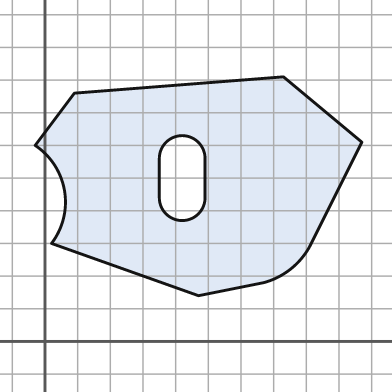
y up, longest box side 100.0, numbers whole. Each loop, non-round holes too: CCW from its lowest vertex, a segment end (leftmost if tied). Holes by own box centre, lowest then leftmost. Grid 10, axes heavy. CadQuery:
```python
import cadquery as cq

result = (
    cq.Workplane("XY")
    .moveTo(47.0, 14.0)
    .lineTo(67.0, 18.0)
    .threePointArc((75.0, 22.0), (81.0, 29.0))
    .lineTo(97.0, 61.0)
    .lineTo(73.0, 81.0)
    .lineTo(9.0, 76.0)
    .lineTo(-3.0, 60.0)
    .threePointArc((6.0, 46.0), (2.0, 30.0))
    .close()
    .moveTo(35.0, 44.0)
    .threePointArc((42.0, 37.0), (49.0, 44.0))
    .lineTo(49.0, 56.0)
    .threePointArc((42.0, 63.0), (35.0, 56.0))
    .close()
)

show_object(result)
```